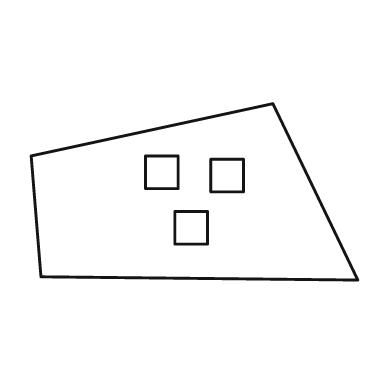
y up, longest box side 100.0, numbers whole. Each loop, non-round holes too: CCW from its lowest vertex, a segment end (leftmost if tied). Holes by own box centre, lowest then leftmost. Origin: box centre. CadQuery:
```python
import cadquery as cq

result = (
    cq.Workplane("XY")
    .moveTo(50.0, -27.0)
    .lineTo(24.0, 27.0)
    .lineTo(-50.0, 11.0)
    .lineTo(-47.0, -26.0)
    .close()
    .moveTo(-6.0, -16.0)
    .lineTo(4.0, -16.0)
    .lineTo(4.0, -6.0)
    .lineTo(-6.0, -6.0)
    .close()
    .moveTo(5.0, 0.0)
    .lineTo(15.0, 0.0)
    .lineTo(15.0, 10.0)
    .lineTo(5.0, 10.0)
    .close()
    .moveTo(-15.0, 1.0)
    .lineTo(-5.0, 1.0)
    .lineTo(-5.0, 11.0)
    .lineTo(-15.0, 11.0)
    .close()
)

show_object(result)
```